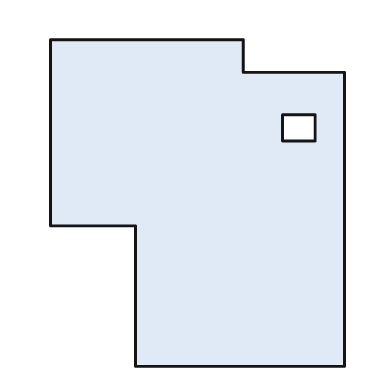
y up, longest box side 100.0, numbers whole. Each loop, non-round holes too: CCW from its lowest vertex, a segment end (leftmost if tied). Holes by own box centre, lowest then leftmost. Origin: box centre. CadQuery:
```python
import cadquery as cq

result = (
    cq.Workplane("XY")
    .moveTo(-19.0, -50.0)
    .lineTo(45.0, -50.0)
    .lineTo(45.0, 40.0)
    .lineTo(14.0, 40.0)
    .lineTo(14.0, 50.0)
    .lineTo(-45.0, 50.0)
    .lineTo(-45.0, -7.0)
    .lineTo(-19.0, -7.0)
    .close()
    .moveTo(26.0, 19.0)
    .lineTo(36.0, 19.0)
    .lineTo(36.0, 27.0)
    .lineTo(26.0, 27.0)
    .close()
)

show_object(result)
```